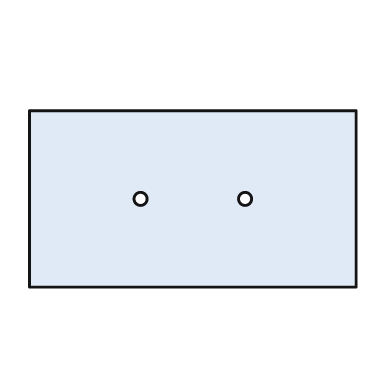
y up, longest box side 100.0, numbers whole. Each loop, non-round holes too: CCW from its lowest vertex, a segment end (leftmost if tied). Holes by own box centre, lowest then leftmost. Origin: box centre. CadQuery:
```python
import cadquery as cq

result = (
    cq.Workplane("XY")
    .moveTo(-50.0, -27.0)
    .lineTo(50.0, -27.0)
    .lineTo(50.0, 27.0)
    .lineTo(-50.0, 27.0)
    .close()
    .moveTo(-16.0, 0.0)
    .circle(2.0)
    .moveTo(16.0, 0.0)
    .circle(2.0)
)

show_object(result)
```